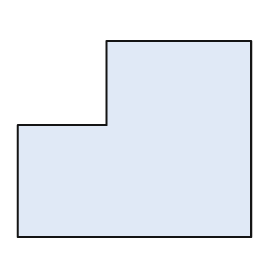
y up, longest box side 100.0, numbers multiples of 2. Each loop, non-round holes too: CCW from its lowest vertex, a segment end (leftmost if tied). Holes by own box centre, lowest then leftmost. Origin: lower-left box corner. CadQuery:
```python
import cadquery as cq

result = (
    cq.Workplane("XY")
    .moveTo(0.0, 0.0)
    .lineTo(100.0, 0.0)
    .lineTo(100.0, 84.0)
    .lineTo(38.0, 84.0)
    .lineTo(38.0, 48.0)
    .lineTo(0.0, 48.0)
    .close()
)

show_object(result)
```